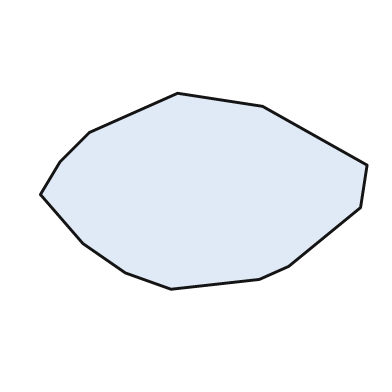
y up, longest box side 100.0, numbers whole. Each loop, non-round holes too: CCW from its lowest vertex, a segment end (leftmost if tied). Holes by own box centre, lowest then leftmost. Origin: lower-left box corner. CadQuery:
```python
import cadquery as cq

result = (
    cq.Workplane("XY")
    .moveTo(40.0, 0.0)
    .lineTo(67.0, 3.0)
    .lineTo(76.0, 7.0)
    .lineTo(98.0, 25.0)
    .lineTo(100.0, 38.0)
    .lineTo(68.0, 56.0)
    .lineTo(42.0, 60.0)
    .lineTo(15.0, 48.0)
    .lineTo(6.0, 39.0)
    .lineTo(0.0, 29.0)
    .lineTo(13.0, 14.0)
    .lineTo(26.0, 5.0)
    .close()
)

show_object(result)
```